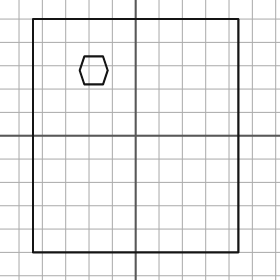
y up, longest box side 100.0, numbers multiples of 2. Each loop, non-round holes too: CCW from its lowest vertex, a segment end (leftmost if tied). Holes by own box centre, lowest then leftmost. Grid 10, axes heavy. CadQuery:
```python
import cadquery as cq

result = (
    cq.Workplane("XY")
    .moveTo(-44.0, -50.0)
    .lineTo(44.0, -50.0)
    .lineTo(44.0, 50.0)
    .lineTo(-44.0, 50.0)
    .close()
    .moveTo(-22.0, 22.0)
    .lineTo(-14.0, 22.0)
    .lineTo(-12.0, 28.0)
    .lineTo(-14.0, 34.0)
    .lineTo(-22.0, 34.0)
    .lineTo(-24.0, 28.0)
    .close()
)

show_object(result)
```